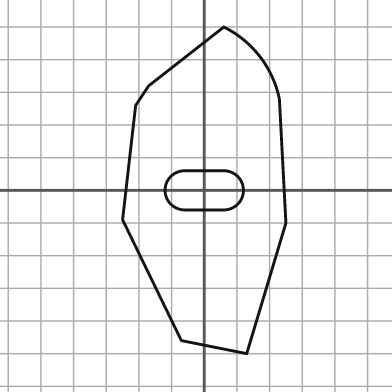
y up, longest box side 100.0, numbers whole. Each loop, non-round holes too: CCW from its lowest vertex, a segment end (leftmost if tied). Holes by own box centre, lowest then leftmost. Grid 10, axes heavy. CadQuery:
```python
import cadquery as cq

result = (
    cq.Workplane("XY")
    .moveTo(13.0, -50.0)
    .lineTo(25.0, -10.0)
    .lineTo(23.0, 28.0)
    .threePointArc((17.0, 41.0), (6.0, 50.0))
    .lineTo(-17.0, 32.0)
    .lineTo(-21.0, 26.0)
    .lineTo(-25.0, -9.0)
    .lineTo(-7.0, -46.0)
    .close()
    .moveTo(-6.0, -6.0)
    .lineTo(6.0, -6.0)
    .threePointArc((12.0, 0.0), (6.0, 6.0))
    .lineTo(-6.0, 6.0)
    .threePointArc((-12.0, 0.0), (-6.0, -6.0))
    .close()
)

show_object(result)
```